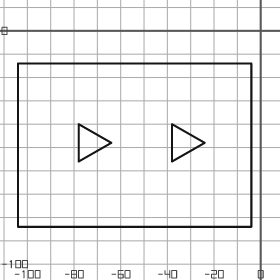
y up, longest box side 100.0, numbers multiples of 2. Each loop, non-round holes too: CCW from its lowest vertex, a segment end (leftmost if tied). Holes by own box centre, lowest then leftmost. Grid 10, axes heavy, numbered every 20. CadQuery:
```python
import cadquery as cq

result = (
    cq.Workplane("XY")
    .moveTo(-104.0, -84.0)
    .lineTo(-4.0, -84.0)
    .lineTo(-4.0, -14.0)
    .lineTo(-104.0, -14.0)
    .close()
    .moveTo(-78.0, -56.0)
    .lineTo(-64.0, -48.0)
    .lineTo(-78.0, -40.0)
    .close()
    .moveTo(-38.0, -56.0)
    .lineTo(-24.0, -48.0)
    .lineTo(-38.0, -40.0)
    .close()
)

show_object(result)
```